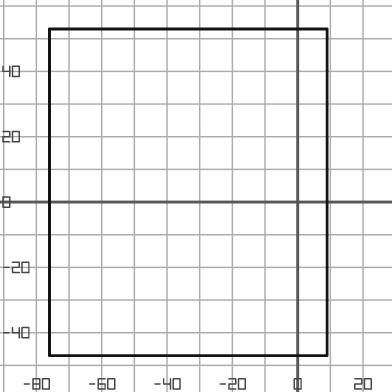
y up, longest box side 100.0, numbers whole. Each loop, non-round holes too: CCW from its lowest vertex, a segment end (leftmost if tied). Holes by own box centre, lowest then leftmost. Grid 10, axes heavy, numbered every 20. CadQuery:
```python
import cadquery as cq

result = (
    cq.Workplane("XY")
    .moveTo(-76.0, -47.0)
    .lineTo(9.0, -47.0)
    .lineTo(9.0, 53.0)
    .lineTo(-76.0, 53.0)
    .close()
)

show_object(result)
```